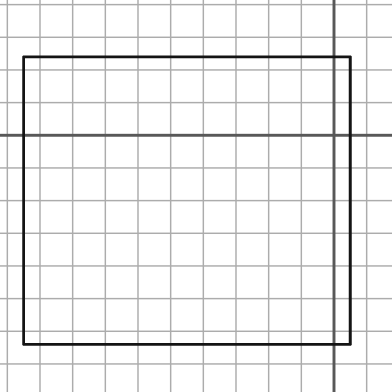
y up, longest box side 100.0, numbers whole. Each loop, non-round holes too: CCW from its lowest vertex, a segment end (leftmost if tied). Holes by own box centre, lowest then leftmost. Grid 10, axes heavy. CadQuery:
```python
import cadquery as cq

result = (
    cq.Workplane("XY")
    .moveTo(-95.0, -64.0)
    .lineTo(5.0, -64.0)
    .lineTo(5.0, 24.0)
    .lineTo(-95.0, 24.0)
    .close()
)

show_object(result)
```